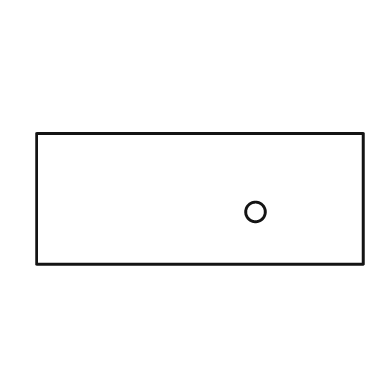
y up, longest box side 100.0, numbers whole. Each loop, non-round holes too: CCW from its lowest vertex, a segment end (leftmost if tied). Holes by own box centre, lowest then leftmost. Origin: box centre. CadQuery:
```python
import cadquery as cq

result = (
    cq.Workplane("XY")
    .moveTo(-50.0, -20.0)
    .lineTo(50.0, -20.0)
    .lineTo(50.0, 20.0)
    .lineTo(-50.0, 20.0)
    .close()
    .moveTo(17.0, -4.0)
    .circle(3.0)
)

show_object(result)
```